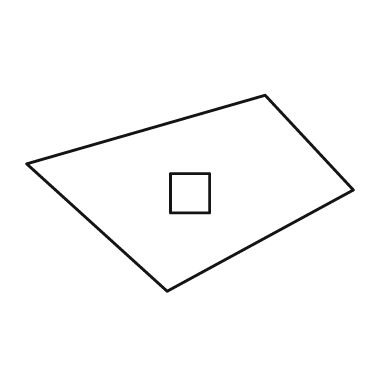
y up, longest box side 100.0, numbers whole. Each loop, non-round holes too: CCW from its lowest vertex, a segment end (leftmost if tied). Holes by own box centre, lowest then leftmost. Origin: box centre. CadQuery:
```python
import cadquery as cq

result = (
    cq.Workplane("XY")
    .moveTo(-7.0, -30.0)
    .lineTo(50.0, 1.0)
    .lineTo(23.0, 30.0)
    .lineTo(-50.0, 9.0)
    .close()
    .moveTo(-6.0, -6.0)
    .lineTo(6.0, -6.0)
    .lineTo(6.0, 6.0)
    .lineTo(-6.0, 6.0)
    .close()
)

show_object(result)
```